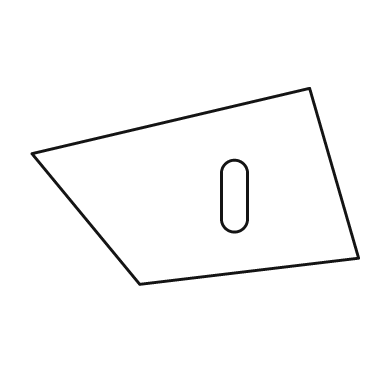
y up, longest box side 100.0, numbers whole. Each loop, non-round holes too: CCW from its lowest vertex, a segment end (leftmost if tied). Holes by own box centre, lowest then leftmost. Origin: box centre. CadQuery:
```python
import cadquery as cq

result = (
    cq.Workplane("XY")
    .moveTo(-17.0, -30.0)
    .lineTo(50.0, -22.0)
    .lineTo(35.0, 30.0)
    .lineTo(-50.0, 10.0)
    .close()
    .moveTo(8.0, -10.0)
    .threePointArc((12.0, -14.0), (16.0, -10.0))
    .lineTo(16.0, 4.0)
    .threePointArc((12.0, 8.0), (8.0, 4.0))
    .close()
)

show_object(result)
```